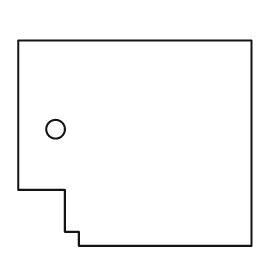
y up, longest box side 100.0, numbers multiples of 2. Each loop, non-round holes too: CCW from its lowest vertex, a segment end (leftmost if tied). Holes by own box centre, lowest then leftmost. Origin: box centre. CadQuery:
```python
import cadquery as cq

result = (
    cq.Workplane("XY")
    .moveTo(-24.0, -44.0)
    .lineTo(50.0, -44.0)
    .lineTo(50.0, 44.0)
    .lineTo(-50.0, 44.0)
    .lineTo(-50.0, -20.0)
    .lineTo(-30.0, -20.0)
    .lineTo(-30.0, -38.0)
    .lineTo(-24.0, -38.0)
    .close()
    .moveTo(-34.0, 6.0)
    .circle(4.0)
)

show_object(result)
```